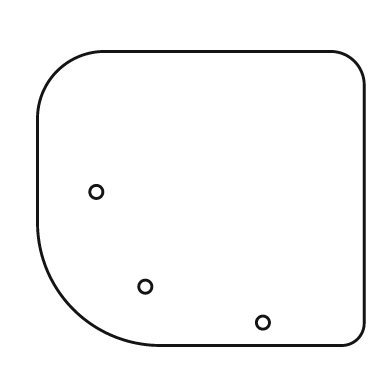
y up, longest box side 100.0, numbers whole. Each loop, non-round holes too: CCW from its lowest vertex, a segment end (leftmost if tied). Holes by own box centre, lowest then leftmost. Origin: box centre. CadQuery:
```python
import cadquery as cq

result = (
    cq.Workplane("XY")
    .moveTo(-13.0, -45.0)
    .lineTo(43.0, -45.0)
    .threePointArc((48.0, -43.0), (50.0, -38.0))
    .lineTo(50.0, 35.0)
    .threePointArc((47.0, 42.0), (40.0, 45.0))
    .lineTo(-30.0, 45.0)
    .threePointArc((-44.0, 39.0), (-50.0, 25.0))
    .lineTo(-50.0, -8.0)
    .threePointArc((-39.0, -34.0), (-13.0, -45.0))
    .close()
    .moveTo(19.0, -38.0)
    .circle(2.0)
    .moveTo(-17.0, -27.0)
    .circle(2.0)
    .moveTo(-32.0, 2.0)
    .circle(2.0)
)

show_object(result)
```